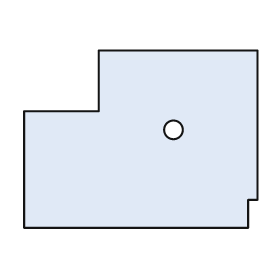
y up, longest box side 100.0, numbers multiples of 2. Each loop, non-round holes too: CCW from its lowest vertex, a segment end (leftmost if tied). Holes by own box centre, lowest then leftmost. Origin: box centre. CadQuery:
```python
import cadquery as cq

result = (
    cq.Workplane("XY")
    .moveTo(-50.0, -38.0)
    .lineTo(46.0, -38.0)
    .lineTo(46.0, -26.0)
    .lineTo(50.0, -26.0)
    .lineTo(50.0, 38.0)
    .lineTo(-18.0, 38.0)
    .lineTo(-18.0, 12.0)
    .lineTo(-50.0, 12.0)
    .close()
    .moveTo(14.0, 4.0)
    .circle(4.0)
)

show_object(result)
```